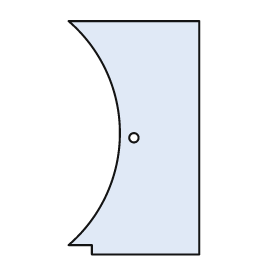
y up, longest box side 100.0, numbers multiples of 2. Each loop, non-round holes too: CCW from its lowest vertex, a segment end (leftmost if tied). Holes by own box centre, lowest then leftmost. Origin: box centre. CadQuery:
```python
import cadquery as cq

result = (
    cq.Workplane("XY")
    .moveTo(-18.0, -50.0)
    .lineTo(28.0, -50.0)
    .lineTo(28.0, 50.0)
    .lineTo(-28.0, 50.0)
    .threePointArc((-6.0, 2.0), (-28.0, -46.0))
    .lineTo(-18.0, -46.0)
    .close()
    .moveTo(0.0, 0.0)
    .circle(2.0)
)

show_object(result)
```